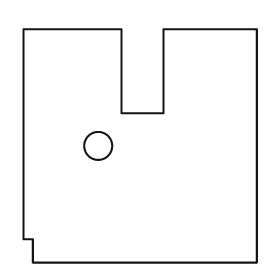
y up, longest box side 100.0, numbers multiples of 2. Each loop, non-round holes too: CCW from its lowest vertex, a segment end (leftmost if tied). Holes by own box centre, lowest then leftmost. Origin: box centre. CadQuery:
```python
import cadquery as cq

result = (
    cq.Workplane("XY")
    .moveTo(-46.0, -50.0)
    .lineTo(50.0, -50.0)
    .lineTo(50.0, 50.0)
    .lineTo(10.0, 50.0)
    .lineTo(10.0, 14.0)
    .lineTo(-8.0, 14.0)
    .lineTo(-8.0, 50.0)
    .lineTo(-50.0, 50.0)
    .lineTo(-50.0, -40.0)
    .lineTo(-46.0, -40.0)
    .close()
    .moveTo(-18.0, 0.0)
    .circle(6.0)
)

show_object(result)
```